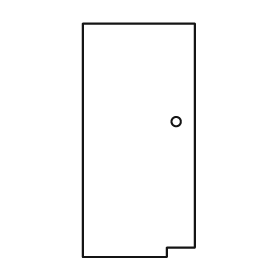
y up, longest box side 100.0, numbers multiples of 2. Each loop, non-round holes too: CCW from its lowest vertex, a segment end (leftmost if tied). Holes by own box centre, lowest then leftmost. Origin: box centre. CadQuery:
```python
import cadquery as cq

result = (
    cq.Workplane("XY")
    .moveTo(-24.0, -50.0)
    .lineTo(12.0, -50.0)
    .lineTo(12.0, -46.0)
    .lineTo(24.0, -46.0)
    .lineTo(24.0, 50.0)
    .lineTo(-24.0, 50.0)
    .close()
    .moveTo(16.0, 8.0)
    .circle(2.0)
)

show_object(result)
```